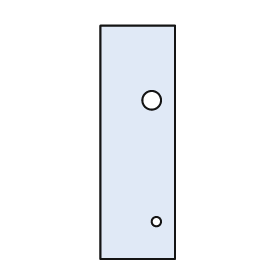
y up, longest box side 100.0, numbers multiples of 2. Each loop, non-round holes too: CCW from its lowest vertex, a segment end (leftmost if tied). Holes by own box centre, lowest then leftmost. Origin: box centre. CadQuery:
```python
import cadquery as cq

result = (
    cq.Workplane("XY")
    .moveTo(-16.0, -50.0)
    .lineTo(16.0, -50.0)
    .lineTo(16.0, 50.0)
    .lineTo(-16.0, 50.0)
    .close()
    .moveTo(8.0, -34.0)
    .circle(2.0)
    .moveTo(6.0, 18.0)
    .circle(4.0)
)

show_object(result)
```